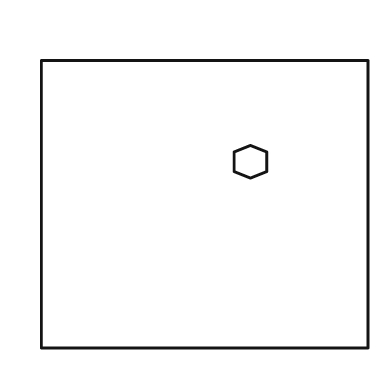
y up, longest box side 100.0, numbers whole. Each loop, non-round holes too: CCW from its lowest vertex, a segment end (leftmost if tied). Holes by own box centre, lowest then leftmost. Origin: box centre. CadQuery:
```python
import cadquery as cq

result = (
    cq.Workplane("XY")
    .moveTo(-50.0, -44.0)
    .lineTo(50.0, -44.0)
    .lineTo(50.0, 44.0)
    .lineTo(-50.0, 44.0)
    .close()
    .moveTo(14.0, 8.0)
    .lineTo(19.0, 10.0)
    .lineTo(19.0, 16.0)
    .lineTo(14.0, 18.0)
    .lineTo(9.0, 16.0)
    .lineTo(9.0, 10.0)
    .close()
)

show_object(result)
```